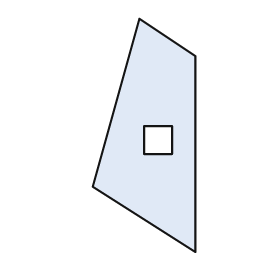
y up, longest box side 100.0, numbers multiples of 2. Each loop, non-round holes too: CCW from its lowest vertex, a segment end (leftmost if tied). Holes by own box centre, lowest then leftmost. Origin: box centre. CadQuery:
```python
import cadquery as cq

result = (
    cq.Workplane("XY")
    .moveTo(22.0, -50.0)
    .lineTo(22.0, 34.0)
    .lineTo(-2.0, 50.0)
    .lineTo(-22.0, -22.0)
    .close()
    .moveTo(0.0, -8.0)
    .lineTo(12.0, -8.0)
    .lineTo(12.0, 4.0)
    .lineTo(0.0, 4.0)
    .close()
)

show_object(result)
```